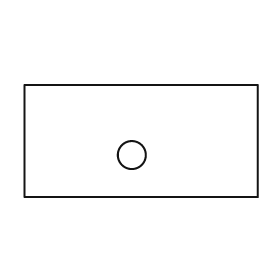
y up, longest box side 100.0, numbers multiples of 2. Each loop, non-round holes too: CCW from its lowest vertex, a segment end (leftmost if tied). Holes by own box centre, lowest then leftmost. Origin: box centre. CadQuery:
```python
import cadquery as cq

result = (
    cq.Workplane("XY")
    .moveTo(-50.0, -24.0)
    .lineTo(50.0, -24.0)
    .lineTo(50.0, 24.0)
    .lineTo(-50.0, 24.0)
    .close()
    .moveTo(-4.0, -6.0)
    .circle(6.0)
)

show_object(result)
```